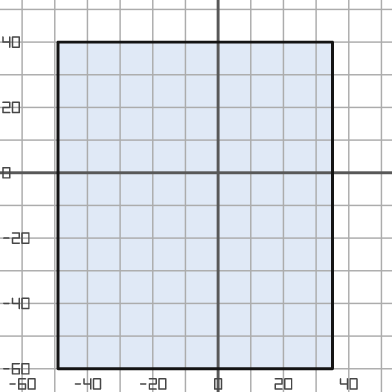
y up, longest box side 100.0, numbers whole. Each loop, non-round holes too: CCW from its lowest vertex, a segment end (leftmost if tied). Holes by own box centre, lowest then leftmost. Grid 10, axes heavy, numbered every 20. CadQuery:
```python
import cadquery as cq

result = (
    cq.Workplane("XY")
    .moveTo(-49.0, -60.0)
    .lineTo(35.0, -60.0)
    .lineTo(35.0, 40.0)
    .lineTo(-49.0, 40.0)
    .close()
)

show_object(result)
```